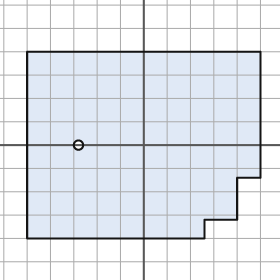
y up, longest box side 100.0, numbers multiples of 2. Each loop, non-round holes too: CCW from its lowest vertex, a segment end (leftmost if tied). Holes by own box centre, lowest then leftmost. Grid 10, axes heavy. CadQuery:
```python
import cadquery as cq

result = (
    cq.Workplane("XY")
    .moveTo(-50.0, -40.0)
    .lineTo(26.0, -40.0)
    .lineTo(26.0, -32.0)
    .lineTo(40.0, -32.0)
    .lineTo(40.0, -14.0)
    .lineTo(50.0, -14.0)
    .lineTo(50.0, 40.0)
    .lineTo(-50.0, 40.0)
    .close()
    .moveTo(-28.0, 0.0)
    .circle(2.0)
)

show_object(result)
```